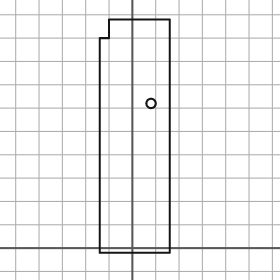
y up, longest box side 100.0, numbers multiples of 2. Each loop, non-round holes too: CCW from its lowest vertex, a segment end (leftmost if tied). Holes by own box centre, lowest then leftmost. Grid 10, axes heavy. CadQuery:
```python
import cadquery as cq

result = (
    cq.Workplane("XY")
    .moveTo(-14.0, -2.0)
    .lineTo(16.0, -2.0)
    .lineTo(16.0, 98.0)
    .lineTo(-10.0, 98.0)
    .lineTo(-10.0, 90.0)
    .lineTo(-14.0, 90.0)
    .close()
    .moveTo(8.0, 62.0)
    .circle(2.0)
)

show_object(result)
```